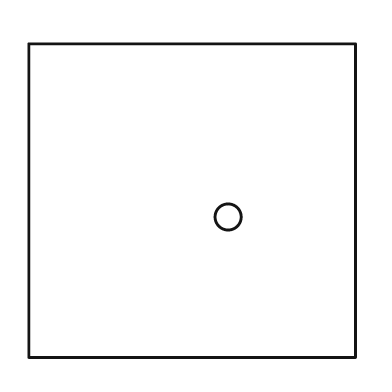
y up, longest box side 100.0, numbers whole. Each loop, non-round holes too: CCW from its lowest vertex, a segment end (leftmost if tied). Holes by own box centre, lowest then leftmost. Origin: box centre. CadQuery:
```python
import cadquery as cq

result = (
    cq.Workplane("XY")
    .moveTo(-50.0, -48.0)
    .lineTo(50.0, -48.0)
    .lineTo(50.0, 48.0)
    .lineTo(-50.0, 48.0)
    .close()
    .moveTo(11.0, -5.0)
    .circle(4.0)
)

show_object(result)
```